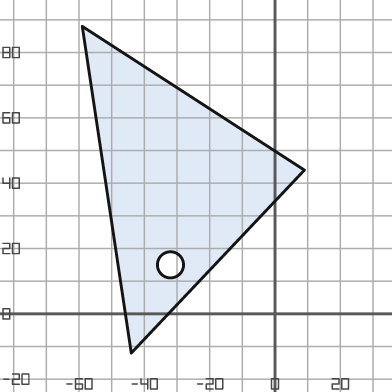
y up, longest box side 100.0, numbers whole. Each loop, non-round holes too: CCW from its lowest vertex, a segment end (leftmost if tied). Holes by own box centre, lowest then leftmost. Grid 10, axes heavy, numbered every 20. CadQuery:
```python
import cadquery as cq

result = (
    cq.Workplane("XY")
    .moveTo(-44.0, -12.0)
    .lineTo(9.0, 44.0)
    .lineTo(-59.0, 88.0)
    .close()
    .moveTo(-32.0, 15.0)
    .circle(4.0)
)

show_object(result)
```